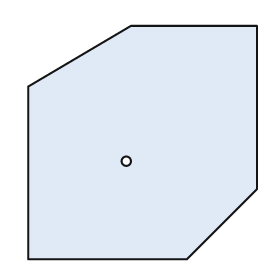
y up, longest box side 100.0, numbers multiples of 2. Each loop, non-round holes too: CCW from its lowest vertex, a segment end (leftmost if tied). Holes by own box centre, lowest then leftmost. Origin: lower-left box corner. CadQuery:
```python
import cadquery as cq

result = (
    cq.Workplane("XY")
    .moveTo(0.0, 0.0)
    .lineTo(68.0, 0.0)
    .lineTo(98.0, 30.0)
    .lineTo(98.0, 100.0)
    .lineTo(44.0, 100.0)
    .lineTo(0.0, 74.0)
    .close()
    .moveTo(42.0, 42.0)
    .circle(2.0)
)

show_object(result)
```